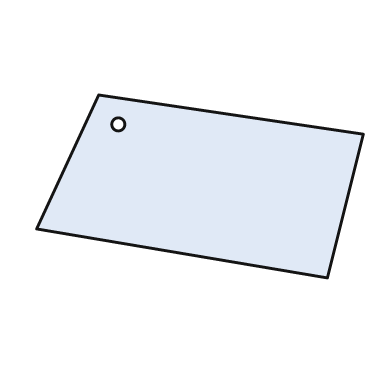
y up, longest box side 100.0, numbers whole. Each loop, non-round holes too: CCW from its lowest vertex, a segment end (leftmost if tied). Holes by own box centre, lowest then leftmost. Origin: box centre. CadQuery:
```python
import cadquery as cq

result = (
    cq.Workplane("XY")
    .moveTo(39.0, -28.0)
    .lineTo(50.0, 16.0)
    .lineTo(-31.0, 28.0)
    .lineTo(-50.0, -13.0)
    .close()
    .moveTo(-25.0, 19.0)
    .circle(2.0)
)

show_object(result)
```